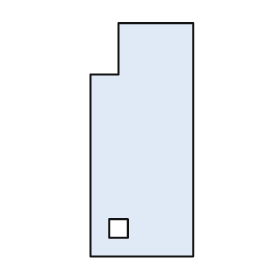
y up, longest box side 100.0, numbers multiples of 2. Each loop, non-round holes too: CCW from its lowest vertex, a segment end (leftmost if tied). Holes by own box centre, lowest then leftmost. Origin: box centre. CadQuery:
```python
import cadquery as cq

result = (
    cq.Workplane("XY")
    .moveTo(-22.0, -50.0)
    .lineTo(22.0, -50.0)
    .lineTo(22.0, 50.0)
    .lineTo(-10.0, 50.0)
    .lineTo(-10.0, 28.0)
    .lineTo(-22.0, 28.0)
    .close()
    .moveTo(-14.0, -42.0)
    .lineTo(-6.0, -42.0)
    .lineTo(-6.0, -34.0)
    .lineTo(-14.0, -34.0)
    .close()
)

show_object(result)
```